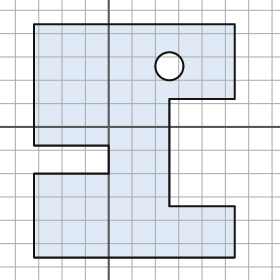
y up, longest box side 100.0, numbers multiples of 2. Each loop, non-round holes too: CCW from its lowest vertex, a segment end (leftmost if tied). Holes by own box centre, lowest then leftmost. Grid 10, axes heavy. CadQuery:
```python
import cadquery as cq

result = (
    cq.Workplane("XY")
    .moveTo(-32.0, -56.0)
    .lineTo(54.0, -56.0)
    .lineTo(54.0, -34.0)
    .lineTo(26.0, -34.0)
    .lineTo(26.0, 12.0)
    .lineTo(54.0, 12.0)
    .lineTo(54.0, 44.0)
    .lineTo(-32.0, 44.0)
    .lineTo(-32.0, -8.0)
    .lineTo(0.0, -8.0)
    .lineTo(0.0, -20.0)
    .lineTo(-32.0, -20.0)
    .close()
    .moveTo(26.0, 26.0)
    .circle(6.0)
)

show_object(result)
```